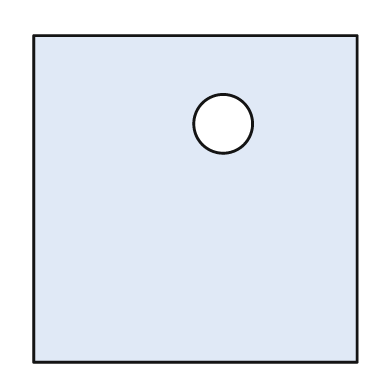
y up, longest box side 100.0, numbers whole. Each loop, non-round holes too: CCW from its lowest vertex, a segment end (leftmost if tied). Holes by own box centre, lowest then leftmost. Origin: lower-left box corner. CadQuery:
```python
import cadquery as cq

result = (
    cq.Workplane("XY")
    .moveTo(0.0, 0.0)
    .lineTo(99.0, 0.0)
    .lineTo(99.0, 100.0)
    .lineTo(0.0, 100.0)
    .close()
    .moveTo(58.0, 73.0)
    .circle(9.0)
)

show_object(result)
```